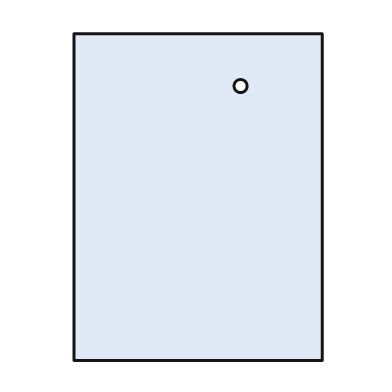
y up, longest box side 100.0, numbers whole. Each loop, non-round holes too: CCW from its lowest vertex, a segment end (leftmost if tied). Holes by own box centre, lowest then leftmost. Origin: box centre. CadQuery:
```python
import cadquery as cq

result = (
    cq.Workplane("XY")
    .moveTo(-38.0, -50.0)
    .lineTo(38.0, -50.0)
    .lineTo(38.0, 50.0)
    .lineTo(-38.0, 50.0)
    .close()
    .moveTo(13.0, 34.0)
    .circle(2.0)
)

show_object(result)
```